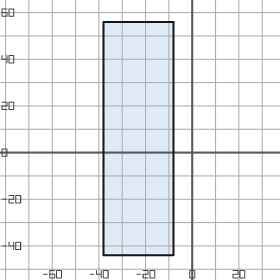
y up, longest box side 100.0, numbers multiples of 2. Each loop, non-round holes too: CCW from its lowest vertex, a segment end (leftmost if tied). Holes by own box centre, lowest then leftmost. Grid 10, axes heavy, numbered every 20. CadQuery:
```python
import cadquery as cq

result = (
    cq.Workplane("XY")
    .moveTo(-38.0, -44.0)
    .lineTo(-8.0, -44.0)
    .lineTo(-8.0, 56.0)
    .lineTo(-38.0, 56.0)
    .close()
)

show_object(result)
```